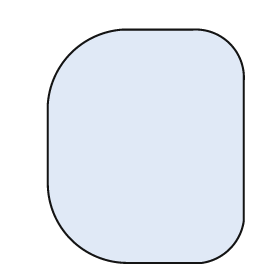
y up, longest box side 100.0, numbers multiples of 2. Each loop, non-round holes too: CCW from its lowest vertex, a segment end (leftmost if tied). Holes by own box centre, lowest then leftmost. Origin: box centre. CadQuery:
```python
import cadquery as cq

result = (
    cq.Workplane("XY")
    .moveTo(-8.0, -50.0)
    .lineTo(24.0, -50.0)
    .threePointArc((36.0, -44.0), (42.0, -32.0))
    .lineTo(42.0, 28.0)
    .threePointArc((36.0, 44.0), (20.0, 50.0))
    .lineTo(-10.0, 50.0)
    .threePointArc((-32.0, 40.0), (-42.0, 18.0))
    .lineTo(-42.0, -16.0)
    .threePointArc((-32.0, -40.0), (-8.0, -50.0))
    .close()
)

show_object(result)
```